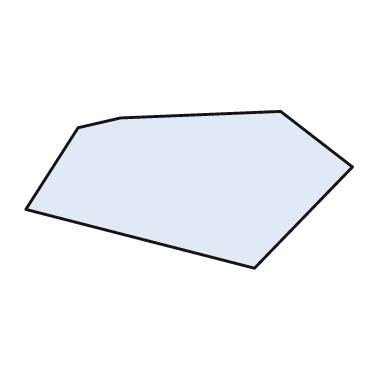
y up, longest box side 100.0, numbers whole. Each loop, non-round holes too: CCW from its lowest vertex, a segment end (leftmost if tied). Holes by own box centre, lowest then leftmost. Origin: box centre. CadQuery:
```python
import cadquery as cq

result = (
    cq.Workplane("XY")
    .moveTo(20.0, -24.0)
    .lineTo(50.0, 7.0)
    .lineTo(28.0, 24.0)
    .lineTo(-21.0, 22.0)
    .lineTo(-34.0, 19.0)
    .lineTo(-50.0, -6.0)
    .close()
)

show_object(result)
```